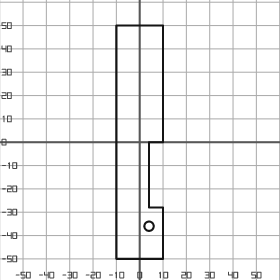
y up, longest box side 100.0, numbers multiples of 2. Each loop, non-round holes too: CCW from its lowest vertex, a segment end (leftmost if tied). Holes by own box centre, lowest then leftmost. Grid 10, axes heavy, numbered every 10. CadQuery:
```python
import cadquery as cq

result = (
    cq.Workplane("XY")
    .moveTo(-10.0, -50.0)
    .lineTo(10.0, -50.0)
    .lineTo(10.0, -28.0)
    .lineTo(4.0, -28.0)
    .lineTo(4.0, 0.0)
    .lineTo(10.0, 0.0)
    .lineTo(10.0, 50.0)
    .lineTo(-10.0, 50.0)
    .close()
    .moveTo(4.0, -36.0)
    .circle(2.0)
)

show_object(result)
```